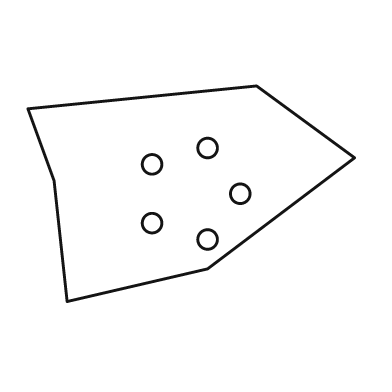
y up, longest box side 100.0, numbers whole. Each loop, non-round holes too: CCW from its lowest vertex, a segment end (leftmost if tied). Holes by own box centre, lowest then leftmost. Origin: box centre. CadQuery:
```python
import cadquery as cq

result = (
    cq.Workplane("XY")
    .moveTo(-38.0, -33.0)
    .lineTo(5.0, -23.0)
    .lineTo(50.0, 11.0)
    .lineTo(20.0, 33.0)
    .lineTo(-50.0, 26.0)
    .lineTo(-42.0, 4.0)
    .close()
    .moveTo(5.0, -14.0)
    .circle(3.0)
    .moveTo(-12.0, -9.0)
    .circle(3.0)
    .moveTo(15.0, 0.0)
    .circle(3.0)
    .moveTo(-12.0, 9.0)
    .circle(3.0)
    .moveTo(5.0, 14.0)
    .circle(3.0)
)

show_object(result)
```